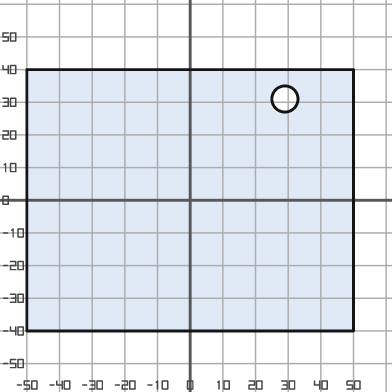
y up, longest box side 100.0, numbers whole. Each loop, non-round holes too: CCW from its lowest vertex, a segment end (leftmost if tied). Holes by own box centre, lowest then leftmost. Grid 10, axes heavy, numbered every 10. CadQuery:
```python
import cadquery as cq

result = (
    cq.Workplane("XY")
    .moveTo(-50.0, -40.0)
    .lineTo(50.0, -40.0)
    .lineTo(50.0, 40.0)
    .lineTo(-50.0, 40.0)
    .close()
    .moveTo(29.0, 31.0)
    .circle(4.0)
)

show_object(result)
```